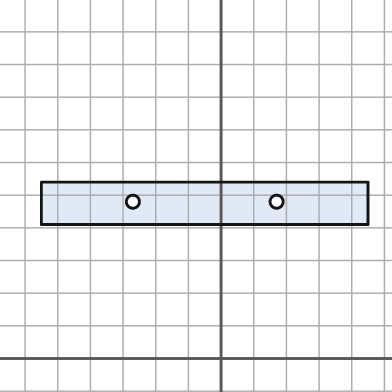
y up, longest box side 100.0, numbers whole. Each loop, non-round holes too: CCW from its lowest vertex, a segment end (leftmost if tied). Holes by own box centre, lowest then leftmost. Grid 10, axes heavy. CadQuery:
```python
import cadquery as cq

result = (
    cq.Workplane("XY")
    .moveTo(-55.0, 41.0)
    .lineTo(45.0, 41.0)
    .lineTo(45.0, 54.0)
    .lineTo(-55.0, 54.0)
    .close()
    .moveTo(-27.0, 48.0)
    .circle(2.0)
    .moveTo(17.0, 48.0)
    .circle(2.0)
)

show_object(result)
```